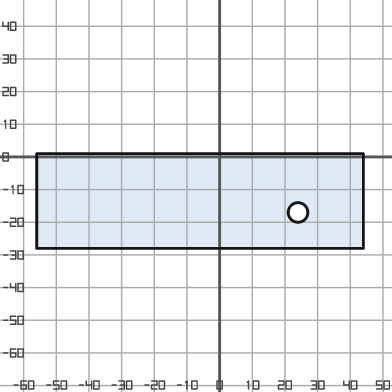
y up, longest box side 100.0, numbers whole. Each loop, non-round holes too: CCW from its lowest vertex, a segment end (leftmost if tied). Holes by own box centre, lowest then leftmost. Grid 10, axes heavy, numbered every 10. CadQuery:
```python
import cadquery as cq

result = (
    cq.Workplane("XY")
    .moveTo(-56.0, -28.0)
    .lineTo(44.0, -28.0)
    .lineTo(44.0, 1.0)
    .lineTo(-56.0, 1.0)
    .close()
    .moveTo(24.0, -17.0)
    .circle(3.0)
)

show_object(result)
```